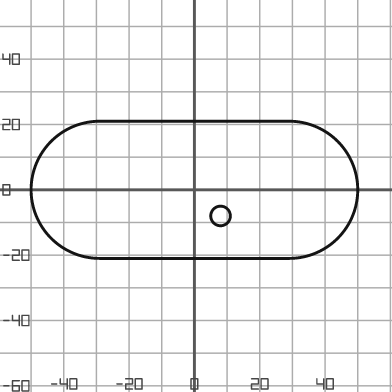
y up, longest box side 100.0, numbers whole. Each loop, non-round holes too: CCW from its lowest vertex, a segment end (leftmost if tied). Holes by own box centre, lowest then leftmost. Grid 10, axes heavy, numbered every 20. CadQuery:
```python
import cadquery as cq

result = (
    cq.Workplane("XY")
    .moveTo(-29.0, -21.0)
    .lineTo(29.0, -21.0)
    .threePointArc((50.0, 0.0), (29.0, 21.0))
    .lineTo(-29.0, 21.0)
    .threePointArc((-50.0, 0.0), (-29.0, -21.0))
    .close()
    .moveTo(8.0, -8.0)
    .circle(3.0)
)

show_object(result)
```